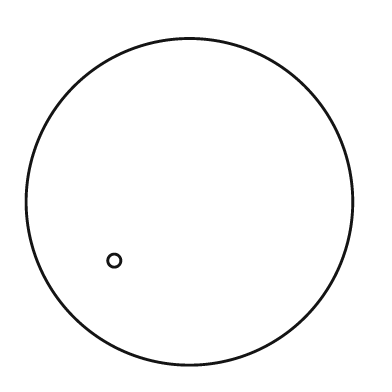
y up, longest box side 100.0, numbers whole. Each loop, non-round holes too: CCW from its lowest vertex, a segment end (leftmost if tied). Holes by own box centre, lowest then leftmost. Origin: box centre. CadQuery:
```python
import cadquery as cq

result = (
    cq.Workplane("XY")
    .moveTo(0.0, 0.0)
    .circle(50.0)
    .moveTo(-23.0, -18.0)
    .circle(2.0)
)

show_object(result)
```